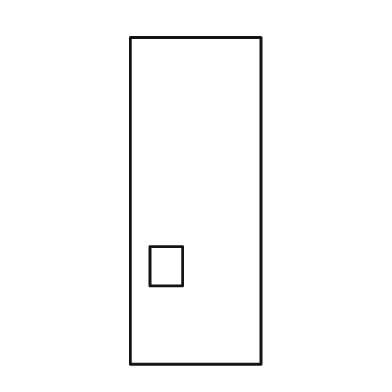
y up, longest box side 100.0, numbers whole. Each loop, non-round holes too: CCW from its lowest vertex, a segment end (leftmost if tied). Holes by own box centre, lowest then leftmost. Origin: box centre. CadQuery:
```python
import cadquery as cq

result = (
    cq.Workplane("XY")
    .moveTo(-20.0, -50.0)
    .lineTo(20.0, -50.0)
    .lineTo(20.0, 50.0)
    .lineTo(-20.0, 50.0)
    .close()
    .moveTo(-14.0, -26.0)
    .lineTo(-4.0, -26.0)
    .lineTo(-4.0, -14.0)
    .lineTo(-14.0, -14.0)
    .close()
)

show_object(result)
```